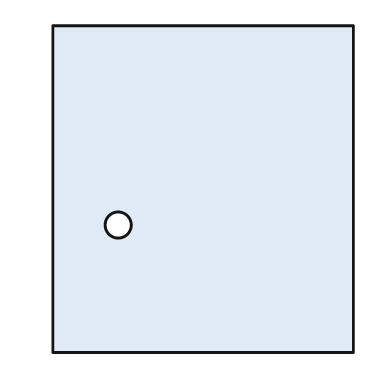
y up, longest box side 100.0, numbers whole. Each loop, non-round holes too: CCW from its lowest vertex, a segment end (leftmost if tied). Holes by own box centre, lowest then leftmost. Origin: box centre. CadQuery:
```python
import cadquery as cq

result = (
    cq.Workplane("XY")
    .moveTo(-46.0, -50.0)
    .lineTo(46.0, -50.0)
    .lineTo(46.0, 50.0)
    .lineTo(-46.0, 50.0)
    .close()
    .moveTo(-26.0, -11.0)
    .circle(4.0)
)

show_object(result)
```